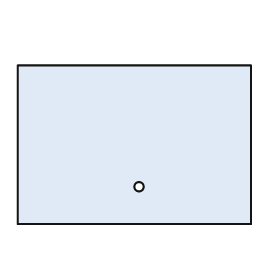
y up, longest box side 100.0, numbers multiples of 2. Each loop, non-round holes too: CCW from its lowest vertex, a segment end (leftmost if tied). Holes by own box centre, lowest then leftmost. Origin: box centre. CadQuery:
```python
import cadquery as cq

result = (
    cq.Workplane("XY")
    .moveTo(-50.0, -34.0)
    .lineTo(50.0, -34.0)
    .lineTo(50.0, 34.0)
    .lineTo(-50.0, 34.0)
    .close()
    .moveTo(2.0, -18.0)
    .circle(2.0)
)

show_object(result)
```